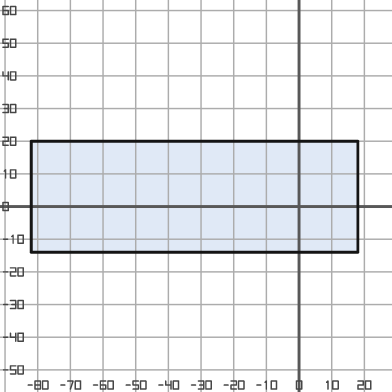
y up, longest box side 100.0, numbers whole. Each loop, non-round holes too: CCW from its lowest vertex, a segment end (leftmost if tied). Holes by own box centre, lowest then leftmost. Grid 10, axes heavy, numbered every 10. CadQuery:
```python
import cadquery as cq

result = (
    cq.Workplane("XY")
    .moveTo(-82.0, -14.0)
    .lineTo(18.0, -14.0)
    .lineTo(18.0, 20.0)
    .lineTo(-82.0, 20.0)
    .close()
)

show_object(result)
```